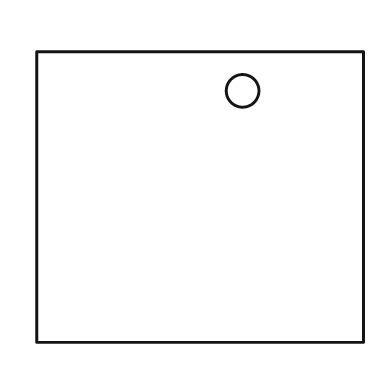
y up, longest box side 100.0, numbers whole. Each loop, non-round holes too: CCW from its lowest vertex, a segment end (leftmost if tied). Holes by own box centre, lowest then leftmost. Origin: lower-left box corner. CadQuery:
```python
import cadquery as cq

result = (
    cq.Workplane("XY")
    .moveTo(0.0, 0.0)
    .lineTo(100.0, 0.0)
    .lineTo(100.0, 89.0)
    .lineTo(0.0, 89.0)
    .close()
    .moveTo(63.0, 77.0)
    .circle(5.0)
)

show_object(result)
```